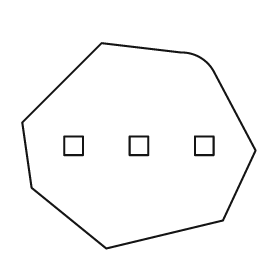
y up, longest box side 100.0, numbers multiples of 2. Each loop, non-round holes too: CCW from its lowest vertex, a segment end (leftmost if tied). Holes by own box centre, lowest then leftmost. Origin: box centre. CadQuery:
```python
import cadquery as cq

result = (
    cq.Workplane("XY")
    .moveTo(-14.0, -44.0)
    .lineTo(36.0, -32.0)
    .lineTo(50.0, -2.0)
    .lineTo(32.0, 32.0)
    .threePointArc((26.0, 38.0), (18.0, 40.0))
    .lineTo(-16.0, 44.0)
    .lineTo(-50.0, 10.0)
    .lineTo(-46.0, -18.0)
    .close()
    .moveTo(-32.0, -4.0)
    .lineTo(-24.0, -4.0)
    .lineTo(-24.0, 4.0)
    .lineTo(-32.0, 4.0)
    .close()
    .moveTo(-4.0, -4.0)
    .lineTo(4.0, -4.0)
    .lineTo(4.0, 4.0)
    .lineTo(-4.0, 4.0)
    .close()
    .moveTo(24.0, -4.0)
    .lineTo(32.0, -4.0)
    .lineTo(32.0, 4.0)
    .lineTo(24.0, 4.0)
    .close()
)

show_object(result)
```